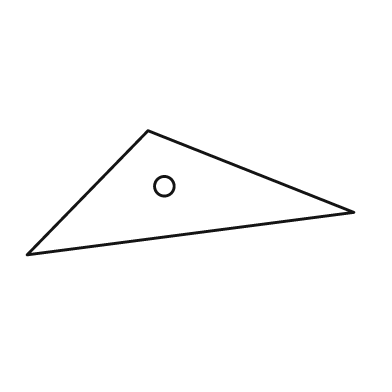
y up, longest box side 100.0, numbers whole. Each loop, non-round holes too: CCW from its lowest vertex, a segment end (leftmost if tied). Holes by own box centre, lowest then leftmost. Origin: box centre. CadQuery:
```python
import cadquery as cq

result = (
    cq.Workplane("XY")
    .moveTo(-50.0, -19.0)
    .lineTo(50.0, -6.0)
    .lineTo(-13.0, 19.0)
    .close()
    .moveTo(-8.0, 2.0)
    .circle(3.0)
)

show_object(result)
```